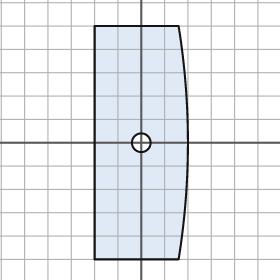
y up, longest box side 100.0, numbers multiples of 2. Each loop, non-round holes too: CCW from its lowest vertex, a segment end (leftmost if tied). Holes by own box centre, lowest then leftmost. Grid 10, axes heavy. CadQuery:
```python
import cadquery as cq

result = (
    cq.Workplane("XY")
    .moveTo(-20.0, -50.0)
    .lineTo(16.0, -50.0)
    .threePointArc((20.0, 0.0), (16.0, 50.0))
    .lineTo(-20.0, 50.0)
    .close()
    .moveTo(0.0, 0.0)
    .circle(4.0)
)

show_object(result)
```